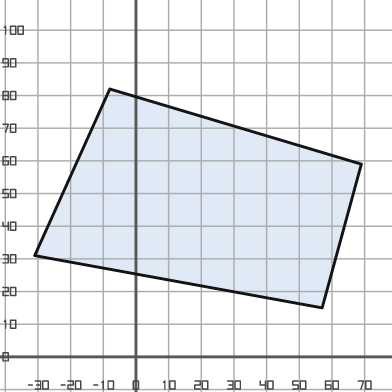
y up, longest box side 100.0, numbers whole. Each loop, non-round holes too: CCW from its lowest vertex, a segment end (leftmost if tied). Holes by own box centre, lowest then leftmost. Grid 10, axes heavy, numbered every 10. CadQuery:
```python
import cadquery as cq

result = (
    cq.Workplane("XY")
    .moveTo(57.0, 15.0)
    .lineTo(69.0, 59.0)
    .lineTo(-8.0, 82.0)
    .lineTo(-31.0, 31.0)
    .close()
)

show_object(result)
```